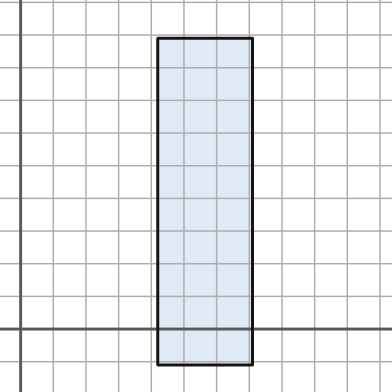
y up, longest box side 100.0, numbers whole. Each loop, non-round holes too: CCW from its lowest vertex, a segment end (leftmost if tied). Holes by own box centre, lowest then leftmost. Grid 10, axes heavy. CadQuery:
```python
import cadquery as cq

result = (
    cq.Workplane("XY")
    .moveTo(42.0, -11.0)
    .lineTo(71.0, -11.0)
    .lineTo(71.0, 89.0)
    .lineTo(42.0, 89.0)
    .close()
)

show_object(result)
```